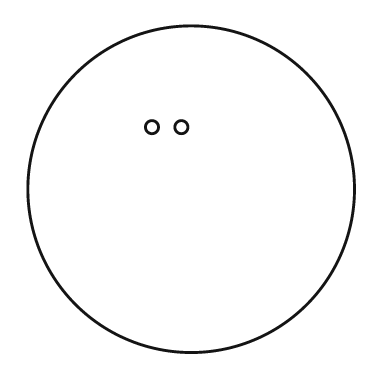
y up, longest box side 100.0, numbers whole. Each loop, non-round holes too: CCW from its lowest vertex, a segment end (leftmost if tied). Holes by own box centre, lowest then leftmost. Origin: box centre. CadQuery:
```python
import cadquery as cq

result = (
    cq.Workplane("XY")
    .moveTo(0.0, 0.0)
    .circle(50.0)
    .moveTo(-12.0, 19.0)
    .circle(2.0)
    .moveTo(-3.0, 19.0)
    .circle(2.0)
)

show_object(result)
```